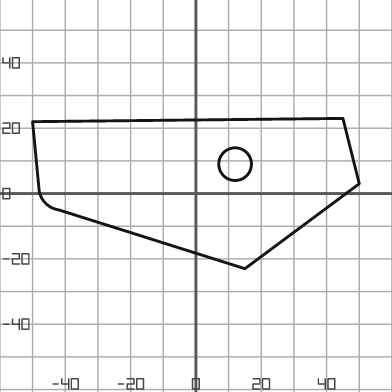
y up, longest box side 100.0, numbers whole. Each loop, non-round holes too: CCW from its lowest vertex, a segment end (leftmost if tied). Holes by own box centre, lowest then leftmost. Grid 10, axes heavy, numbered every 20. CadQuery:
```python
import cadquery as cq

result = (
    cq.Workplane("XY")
    .moveTo(15.0, -23.0)
    .lineTo(50.0, 3.0)
    .lineTo(45.0, 23.0)
    .lineTo(-50.0, 22.0)
    .lineTo(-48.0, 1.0)
    .threePointArc((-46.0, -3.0), (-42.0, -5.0))
    .close()
    .moveTo(12.0, 9.0)
    .circle(5.0)
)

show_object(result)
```